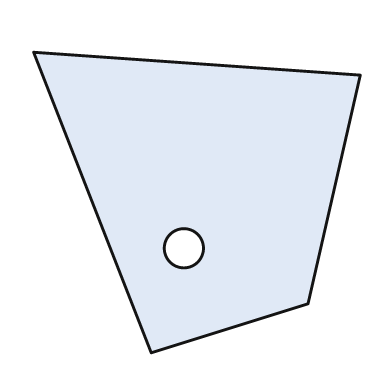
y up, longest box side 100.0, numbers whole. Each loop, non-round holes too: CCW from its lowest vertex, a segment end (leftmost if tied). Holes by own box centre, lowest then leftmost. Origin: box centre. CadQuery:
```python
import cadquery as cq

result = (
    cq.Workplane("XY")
    .moveTo(-14.0, -46.0)
    .lineTo(34.0, -31.0)
    .lineTo(50.0, 39.0)
    .lineTo(-50.0, 46.0)
    .close()
    .moveTo(-4.0, -14.0)
    .circle(6.0)
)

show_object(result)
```